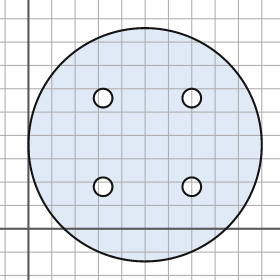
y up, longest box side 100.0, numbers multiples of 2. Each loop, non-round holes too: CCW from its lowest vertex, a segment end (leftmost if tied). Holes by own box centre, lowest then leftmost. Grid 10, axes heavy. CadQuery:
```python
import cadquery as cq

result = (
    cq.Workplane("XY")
    .moveTo(50.0, 36.0)
    .circle(50.0)
    .moveTo(32.0, 18.0)
    .circle(4.0)
    .moveTo(70.0, 18.0)
    .circle(4.0)
    .moveTo(32.0, 56.0)
    .circle(4.0)
    .moveTo(70.0, 56.0)
    .circle(4.0)
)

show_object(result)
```